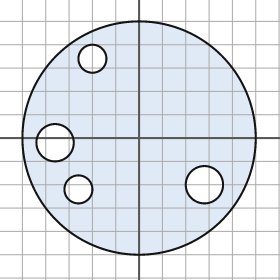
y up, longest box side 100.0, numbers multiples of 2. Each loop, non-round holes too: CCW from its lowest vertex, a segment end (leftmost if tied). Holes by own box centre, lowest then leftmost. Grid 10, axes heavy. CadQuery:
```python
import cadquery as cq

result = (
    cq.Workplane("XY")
    .moveTo(0.0, 0.0)
    .circle(50.0)
    .moveTo(-26.0, -22.0)
    .circle(6.0)
    .moveTo(28.0, -20.0)
    .circle(8.0)
    .moveTo(-36.0, -2.0)
    .circle(8.0)
    .moveTo(-20.0, 34.0)
    .circle(6.0)
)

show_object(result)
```